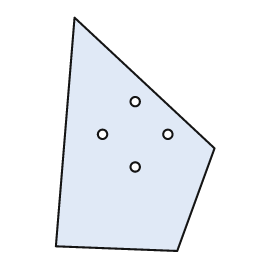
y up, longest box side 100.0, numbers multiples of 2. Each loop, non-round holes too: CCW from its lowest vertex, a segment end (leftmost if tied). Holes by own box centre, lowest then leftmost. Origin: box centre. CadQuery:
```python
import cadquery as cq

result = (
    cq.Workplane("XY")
    .moveTo(18.0, -50.0)
    .lineTo(34.0, -6.0)
    .lineTo(-26.0, 50.0)
    .lineTo(-34.0, -48.0)
    .close()
    .moveTo(0.0, -14.0)
    .circle(2.0)
    .moveTo(-14.0, 0.0)
    .circle(2.0)
    .moveTo(14.0, 0.0)
    .circle(2.0)
    .moveTo(0.0, 14.0)
    .circle(2.0)
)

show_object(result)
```